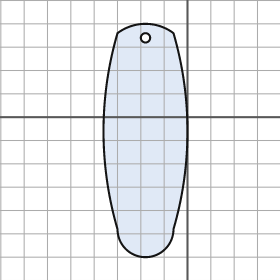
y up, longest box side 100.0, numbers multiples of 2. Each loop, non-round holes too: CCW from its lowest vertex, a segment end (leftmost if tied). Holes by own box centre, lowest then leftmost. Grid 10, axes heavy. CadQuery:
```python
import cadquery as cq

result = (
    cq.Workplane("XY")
    .moveTo(-30.0, -48.0)
    .threePointArc((-18.0, -60.0), (-6.0, -48.0))
    .threePointArc((0.0, -6.0), (-6.0, 36.0))
    .threePointArc((-18.0, 40.0), (-30.0, 36.0))
    .threePointArc((-36.0, -6.0), (-30.0, -48.0))
    .close()
    .moveTo(-18.0, 34.0)
    .circle(2.0)
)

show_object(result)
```